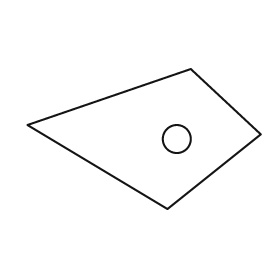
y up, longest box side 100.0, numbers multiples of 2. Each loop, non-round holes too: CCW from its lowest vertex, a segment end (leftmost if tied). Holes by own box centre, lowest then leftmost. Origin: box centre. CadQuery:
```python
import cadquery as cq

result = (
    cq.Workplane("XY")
    .moveTo(10.0, -30.0)
    .lineTo(50.0, 2.0)
    .lineTo(20.0, 30.0)
    .lineTo(-50.0, 6.0)
    .close()
    .moveTo(14.0, 0.0)
    .circle(6.0)
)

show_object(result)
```